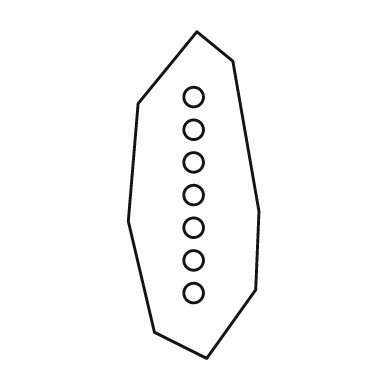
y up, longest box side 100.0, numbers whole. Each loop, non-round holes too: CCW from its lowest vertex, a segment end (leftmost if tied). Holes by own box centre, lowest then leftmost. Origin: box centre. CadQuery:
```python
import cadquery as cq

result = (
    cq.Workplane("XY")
    .moveTo(4.0, -50.0)
    .lineTo(19.0, -29.0)
    .lineTo(20.0, -5.0)
    .lineTo(12.0, 41.0)
    .lineTo(1.0, 50.0)
    .lineTo(-17.0, 28.0)
    .lineTo(-20.0, -8.0)
    .lineTo(-12.0, -42.0)
    .close()
    .moveTo(0.0, -30.0)
    .circle(3.0)
    .moveTo(0.0, -20.0)
    .circle(3.0)
    .moveTo(0.0, -10.0)
    .circle(3.0)
    .moveTo(0.0, 0.0)
    .circle(3.0)
    .moveTo(0.0, 10.0)
    .circle(3.0)
    .moveTo(0.0, 20.0)
    .circle(3.0)
    .moveTo(0.0, 30.0)
    .circle(3.0)
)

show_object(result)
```